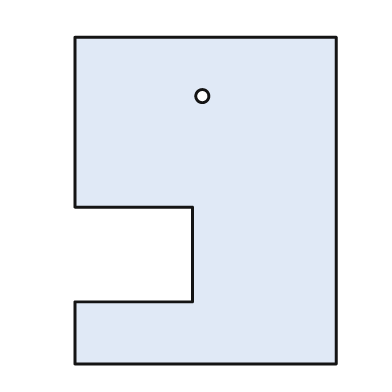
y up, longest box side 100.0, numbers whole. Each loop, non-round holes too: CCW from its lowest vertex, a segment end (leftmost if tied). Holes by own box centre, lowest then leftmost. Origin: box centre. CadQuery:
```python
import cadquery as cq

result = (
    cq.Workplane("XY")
    .moveTo(-40.0, -50.0)
    .lineTo(40.0, -50.0)
    .lineTo(40.0, 50.0)
    .lineTo(-40.0, 50.0)
    .lineTo(-40.0, -2.0)
    .lineTo(-4.0, -2.0)
    .lineTo(-4.0, -31.0)
    .lineTo(-40.0, -31.0)
    .close()
    .moveTo(-1.0, 32.0)
    .circle(2.0)
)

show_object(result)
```